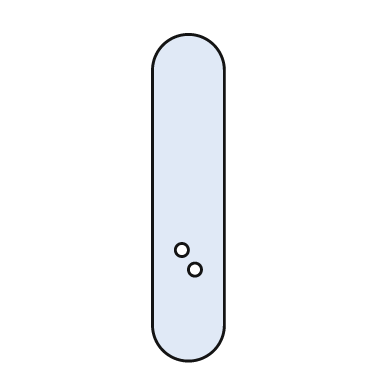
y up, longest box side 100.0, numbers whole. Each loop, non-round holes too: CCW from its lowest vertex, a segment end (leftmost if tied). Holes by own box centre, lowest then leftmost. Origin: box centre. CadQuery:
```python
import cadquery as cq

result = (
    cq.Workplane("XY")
    .moveTo(-11.0, -39.0)
    .threePointArc((0.0, -50.0), (11.0, -39.0))
    .lineTo(11.0, 39.0)
    .threePointArc((0.0, 50.0), (-11.0, 39.0))
    .close()
    .moveTo(2.0, -22.0)
    .circle(2.0)
    .moveTo(-2.0, -16.0)
    .circle(2.0)
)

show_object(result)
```